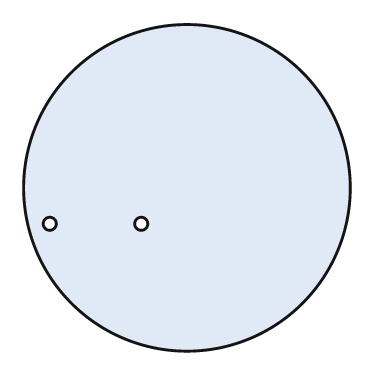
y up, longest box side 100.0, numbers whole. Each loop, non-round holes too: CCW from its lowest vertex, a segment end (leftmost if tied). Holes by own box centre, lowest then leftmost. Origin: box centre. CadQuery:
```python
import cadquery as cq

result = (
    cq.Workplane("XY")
    .moveTo(0.0, 0.0)
    .circle(50.0)
    .moveTo(-42.0, -11.0)
    .circle(2.0)
    .moveTo(-14.0, -11.0)
    .circle(2.0)
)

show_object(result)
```